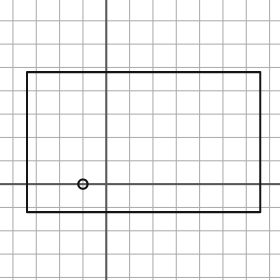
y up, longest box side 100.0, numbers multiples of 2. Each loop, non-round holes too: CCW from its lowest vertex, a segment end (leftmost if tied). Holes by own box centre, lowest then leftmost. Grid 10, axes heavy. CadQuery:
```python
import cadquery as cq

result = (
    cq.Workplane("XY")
    .moveTo(-34.0, -12.0)
    .lineTo(66.0, -12.0)
    .lineTo(66.0, 48.0)
    .lineTo(-34.0, 48.0)
    .close()
    .moveTo(-10.0, 0.0)
    .circle(2.0)
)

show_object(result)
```